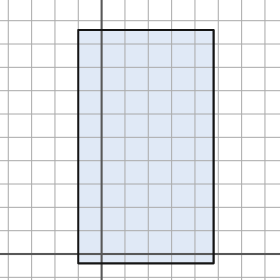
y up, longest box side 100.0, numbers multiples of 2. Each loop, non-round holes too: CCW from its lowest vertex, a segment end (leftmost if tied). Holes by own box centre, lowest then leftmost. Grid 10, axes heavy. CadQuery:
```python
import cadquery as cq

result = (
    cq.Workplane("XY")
    .moveTo(-10.0, -4.0)
    .lineTo(48.0, -4.0)
    .lineTo(48.0, 96.0)
    .lineTo(-10.0, 96.0)
    .close()
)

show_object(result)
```